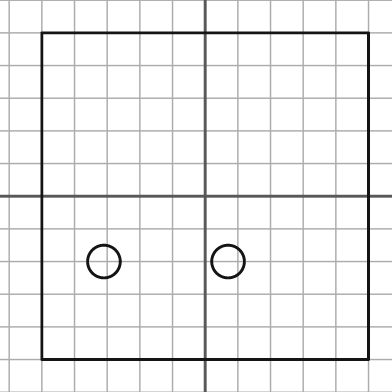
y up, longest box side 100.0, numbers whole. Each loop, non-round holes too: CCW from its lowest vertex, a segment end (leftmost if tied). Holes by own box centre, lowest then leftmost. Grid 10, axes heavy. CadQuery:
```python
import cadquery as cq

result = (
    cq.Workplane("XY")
    .moveTo(-50.0, -50.0)
    .lineTo(50.0, -50.0)
    .lineTo(50.0, 50.0)
    .lineTo(-50.0, 50.0)
    .close()
    .moveTo(-31.0, -20.0)
    .circle(5.0)
    .moveTo(7.0, -20.0)
    .circle(5.0)
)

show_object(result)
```